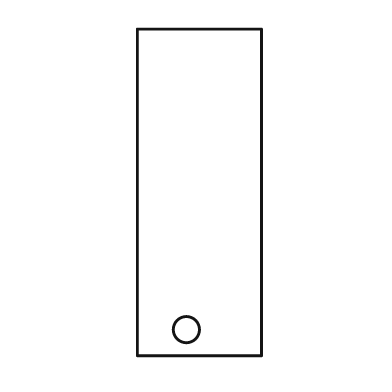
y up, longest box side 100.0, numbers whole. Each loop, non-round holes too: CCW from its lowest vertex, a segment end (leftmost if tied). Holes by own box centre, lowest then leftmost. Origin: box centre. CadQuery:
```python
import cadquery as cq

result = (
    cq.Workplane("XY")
    .moveTo(-19.0, -50.0)
    .lineTo(19.0, -50.0)
    .lineTo(19.0, 50.0)
    .lineTo(-19.0, 50.0)
    .close()
    .moveTo(-4.0, -42.0)
    .circle(4.0)
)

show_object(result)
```